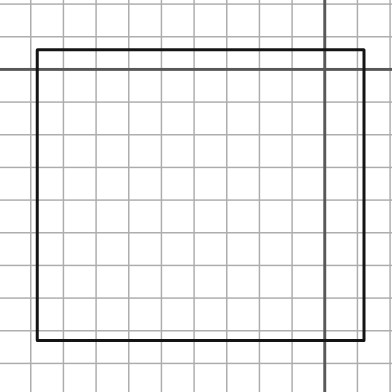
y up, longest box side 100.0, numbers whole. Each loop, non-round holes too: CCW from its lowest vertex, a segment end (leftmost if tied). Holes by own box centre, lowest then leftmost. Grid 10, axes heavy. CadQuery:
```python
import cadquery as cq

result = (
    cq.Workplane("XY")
    .moveTo(-88.0, -83.0)
    .lineTo(12.0, -83.0)
    .lineTo(12.0, 6.0)
    .lineTo(-88.0, 6.0)
    .close()
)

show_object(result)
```